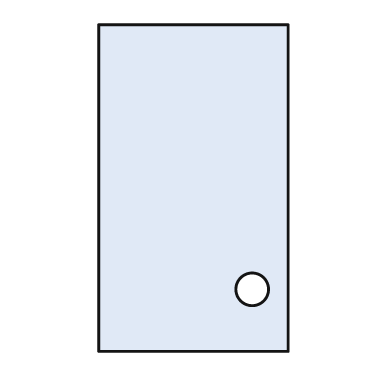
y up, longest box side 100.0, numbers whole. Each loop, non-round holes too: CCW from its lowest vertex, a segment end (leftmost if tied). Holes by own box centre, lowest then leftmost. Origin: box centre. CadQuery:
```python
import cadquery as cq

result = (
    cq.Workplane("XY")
    .moveTo(-29.0, -50.0)
    .lineTo(29.0, -50.0)
    .lineTo(29.0, 50.0)
    .lineTo(-29.0, 50.0)
    .close()
    .moveTo(18.0, -31.0)
    .circle(5.0)
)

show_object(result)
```